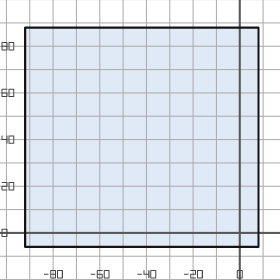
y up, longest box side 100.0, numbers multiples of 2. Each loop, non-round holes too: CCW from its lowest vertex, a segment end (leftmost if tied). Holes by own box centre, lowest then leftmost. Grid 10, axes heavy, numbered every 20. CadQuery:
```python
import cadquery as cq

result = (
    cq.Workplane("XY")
    .moveTo(-92.0, -6.0)
    .lineTo(8.0, -6.0)
    .lineTo(8.0, 88.0)
    .lineTo(-92.0, 88.0)
    .close()
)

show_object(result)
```